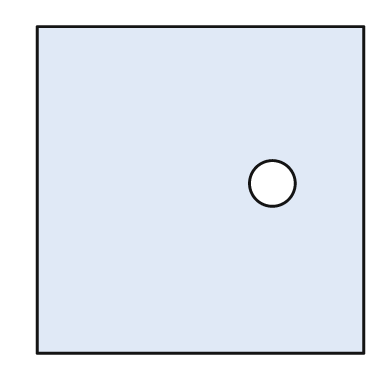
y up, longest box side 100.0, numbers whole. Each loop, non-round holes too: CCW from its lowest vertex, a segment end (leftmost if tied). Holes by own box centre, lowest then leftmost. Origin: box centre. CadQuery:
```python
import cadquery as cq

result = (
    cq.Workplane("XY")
    .moveTo(-50.0, -50.0)
    .lineTo(50.0, -50.0)
    .lineTo(50.0, 50.0)
    .lineTo(-50.0, 50.0)
    .close()
    .moveTo(22.0, 2.0)
    .circle(7.0)
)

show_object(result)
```